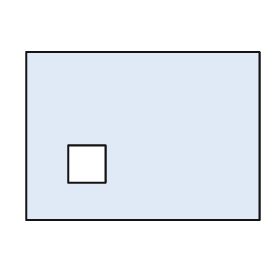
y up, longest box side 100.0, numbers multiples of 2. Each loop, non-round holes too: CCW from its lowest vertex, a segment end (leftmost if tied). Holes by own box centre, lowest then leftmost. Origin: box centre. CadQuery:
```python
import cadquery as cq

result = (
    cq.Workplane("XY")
    .moveTo(-50.0, -36.0)
    .lineTo(50.0, -36.0)
    .lineTo(50.0, 36.0)
    .lineTo(-50.0, 36.0)
    .close()
    .moveTo(-32.0, -20.0)
    .lineTo(-16.0, -20.0)
    .lineTo(-16.0, -4.0)
    .lineTo(-32.0, -4.0)
    .close()
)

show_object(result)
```